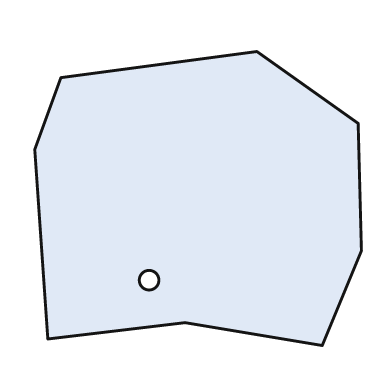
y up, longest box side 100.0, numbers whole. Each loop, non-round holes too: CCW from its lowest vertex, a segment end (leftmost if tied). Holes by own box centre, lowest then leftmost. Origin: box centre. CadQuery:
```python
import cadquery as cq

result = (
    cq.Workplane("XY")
    .moveTo(38.0, -45.0)
    .lineTo(50.0, -16.0)
    .lineTo(49.0, 23.0)
    .lineTo(18.0, 45.0)
    .lineTo(-42.0, 37.0)
    .lineTo(-50.0, 15.0)
    .lineTo(-46.0, -43.0)
    .lineTo(-4.0, -38.0)
    .close()
    .moveTo(-15.0, -25.0)
    .circle(3.0)
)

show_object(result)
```